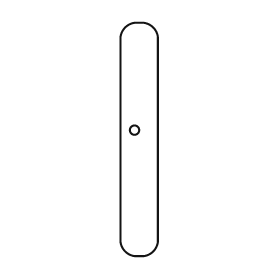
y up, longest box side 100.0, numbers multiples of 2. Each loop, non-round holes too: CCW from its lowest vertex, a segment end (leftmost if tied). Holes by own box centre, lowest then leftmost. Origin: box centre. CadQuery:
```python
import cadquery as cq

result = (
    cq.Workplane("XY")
    .moveTo(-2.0, -50.0)
    .lineTo(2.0, -50.0)
    .threePointArc((6.0, -48.0), (8.0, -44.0))
    .lineTo(8.0, 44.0)
    .threePointArc((6.0, 48.0), (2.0, 50.0))
    .lineTo(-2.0, 50.0)
    .threePointArc((-6.0, 48.0), (-8.0, 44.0))
    .lineTo(-8.0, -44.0)
    .threePointArc((-6.0, -48.0), (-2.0, -50.0))
    .close()
    .moveTo(-2.0, 4.0)
    .circle(2.0)
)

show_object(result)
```